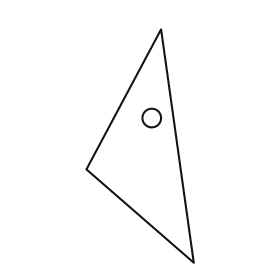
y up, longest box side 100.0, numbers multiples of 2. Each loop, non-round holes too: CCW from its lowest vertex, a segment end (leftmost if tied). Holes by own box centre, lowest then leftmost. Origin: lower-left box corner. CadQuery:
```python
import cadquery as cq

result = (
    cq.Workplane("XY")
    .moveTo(46.0, 0.0)
    .lineTo(32.0, 100.0)
    .lineTo(0.0, 40.0)
    .close()
    .moveTo(28.0, 62.0)
    .circle(4.0)
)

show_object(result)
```